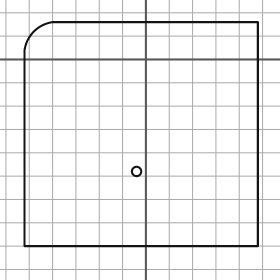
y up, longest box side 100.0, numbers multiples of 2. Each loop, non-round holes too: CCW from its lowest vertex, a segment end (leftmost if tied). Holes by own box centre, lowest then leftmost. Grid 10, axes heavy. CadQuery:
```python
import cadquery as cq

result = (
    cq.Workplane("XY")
    .moveTo(-52.0, -80.0)
    .lineTo(48.0, -80.0)
    .lineTo(48.0, 16.0)
    .lineTo(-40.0, 16.0)
    .threePointArc((-48.0, 12.0), (-52.0, 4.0))
    .close()
    .moveTo(-4.0, -48.0)
    .circle(2.0)
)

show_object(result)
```